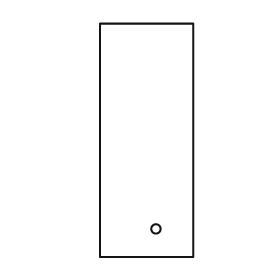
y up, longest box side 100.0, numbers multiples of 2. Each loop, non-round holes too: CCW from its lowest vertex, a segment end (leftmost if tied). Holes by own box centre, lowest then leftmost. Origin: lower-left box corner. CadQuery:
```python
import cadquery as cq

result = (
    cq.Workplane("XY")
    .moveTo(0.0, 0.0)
    .lineTo(40.0, 0.0)
    .lineTo(40.0, 100.0)
    .lineTo(0.0, 100.0)
    .close()
    .moveTo(24.0, 12.0)
    .circle(2.0)
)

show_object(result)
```